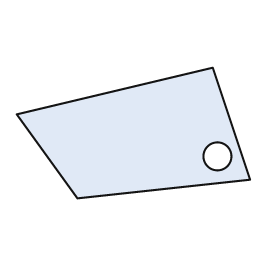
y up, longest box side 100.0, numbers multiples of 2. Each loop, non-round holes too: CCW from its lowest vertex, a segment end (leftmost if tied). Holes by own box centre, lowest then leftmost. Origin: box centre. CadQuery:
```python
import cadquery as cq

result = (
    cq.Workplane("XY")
    .moveTo(-24.0, -28.0)
    .lineTo(50.0, -20.0)
    .lineTo(34.0, 28.0)
    .lineTo(-50.0, 8.0)
    .close()
    .moveTo(36.0, -10.0)
    .circle(6.0)
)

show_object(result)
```